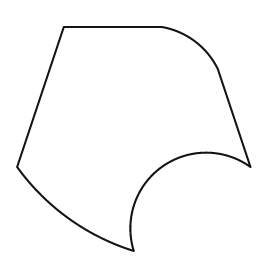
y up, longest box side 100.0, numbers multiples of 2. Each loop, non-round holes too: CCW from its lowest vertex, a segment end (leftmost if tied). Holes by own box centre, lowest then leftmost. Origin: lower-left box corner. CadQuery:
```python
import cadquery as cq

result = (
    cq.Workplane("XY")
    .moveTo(50.0, 0.0)
    .threePointArc((62.0, 36.0), (100.0, 36.0))
    .lineTo(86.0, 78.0)
    .threePointArc((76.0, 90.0), (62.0, 96.0))
    .lineTo(20.0, 96.0)
    .lineTo(0.0, 36.0)
    .threePointArc((22.0, 14.0), (50.0, 0.0))
    .close()
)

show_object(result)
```